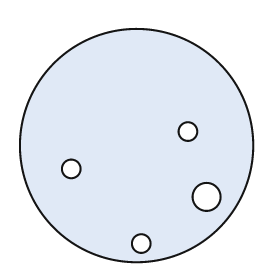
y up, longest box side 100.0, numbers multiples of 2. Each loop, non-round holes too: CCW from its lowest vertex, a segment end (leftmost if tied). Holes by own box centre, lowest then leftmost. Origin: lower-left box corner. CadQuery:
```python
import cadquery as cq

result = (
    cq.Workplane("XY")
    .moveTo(50.0, 50.0)
    .circle(50.0)
    .moveTo(52.0, 8.0)
    .circle(4.0)
    .moveTo(80.0, 28.0)
    .circle(6.0)
    .moveTo(22.0, 40.0)
    .circle(4.0)
    .moveTo(72.0, 56.0)
    .circle(4.0)
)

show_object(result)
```